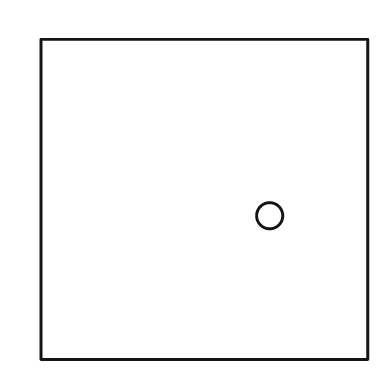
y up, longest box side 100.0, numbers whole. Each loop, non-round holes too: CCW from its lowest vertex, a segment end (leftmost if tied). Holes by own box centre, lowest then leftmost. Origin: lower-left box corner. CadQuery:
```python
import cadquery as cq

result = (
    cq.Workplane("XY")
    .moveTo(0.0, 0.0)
    .lineTo(100.0, 0.0)
    .lineTo(100.0, 98.0)
    .lineTo(0.0, 98.0)
    .close()
    .moveTo(70.0, 44.0)
    .circle(4.0)
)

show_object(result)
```